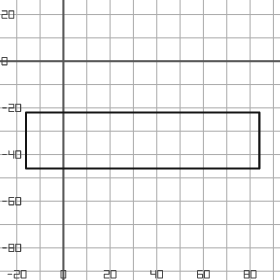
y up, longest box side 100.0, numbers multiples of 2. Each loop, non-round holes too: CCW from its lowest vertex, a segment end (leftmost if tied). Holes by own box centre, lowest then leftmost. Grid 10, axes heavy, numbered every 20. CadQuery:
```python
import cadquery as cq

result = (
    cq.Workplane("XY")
    .moveTo(-16.0, -46.0)
    .lineTo(84.0, -46.0)
    .lineTo(84.0, -22.0)
    .lineTo(-16.0, -22.0)
    .close()
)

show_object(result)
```